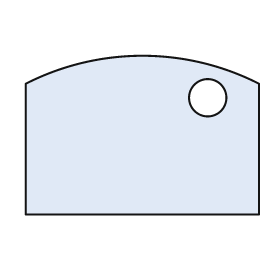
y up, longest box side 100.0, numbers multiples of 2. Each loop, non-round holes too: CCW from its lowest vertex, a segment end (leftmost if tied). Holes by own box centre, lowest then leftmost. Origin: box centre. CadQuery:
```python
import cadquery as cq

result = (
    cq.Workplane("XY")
    .moveTo(-50.0, -34.0)
    .lineTo(50.0, -34.0)
    .lineTo(50.0, 22.0)
    .threePointArc((0.0, 34.0), (-50.0, 22.0))
    .close()
    .moveTo(28.0, 16.0)
    .circle(8.0)
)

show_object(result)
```